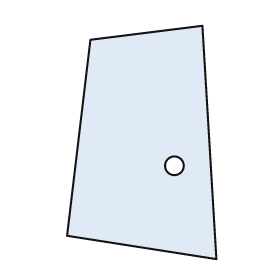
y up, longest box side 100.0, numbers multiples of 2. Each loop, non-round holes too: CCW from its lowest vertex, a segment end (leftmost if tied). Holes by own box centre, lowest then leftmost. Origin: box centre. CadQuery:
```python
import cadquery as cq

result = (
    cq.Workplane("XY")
    .moveTo(32.0, -50.0)
    .lineTo(26.0, 50.0)
    .lineTo(-22.0, 44.0)
    .lineTo(-32.0, -40.0)
    .close()
    .moveTo(14.0, -10.0)
    .circle(4.0)
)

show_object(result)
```